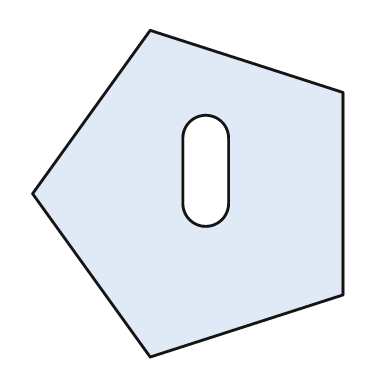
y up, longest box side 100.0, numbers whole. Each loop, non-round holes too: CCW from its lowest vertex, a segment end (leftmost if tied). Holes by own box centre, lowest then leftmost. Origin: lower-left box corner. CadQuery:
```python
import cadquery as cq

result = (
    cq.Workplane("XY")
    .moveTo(36.0, 0.0)
    .lineTo(95.0, 19.0)
    .lineTo(95.0, 81.0)
    .lineTo(36.0, 100.0)
    .lineTo(0.0, 50.0)
    .close()
    .moveTo(46.0, 47.0)
    .threePointArc((53.0, 40.0), (60.0, 47.0))
    .lineTo(60.0, 67.0)
    .threePointArc((53.0, 74.0), (46.0, 67.0))
    .close()
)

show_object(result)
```